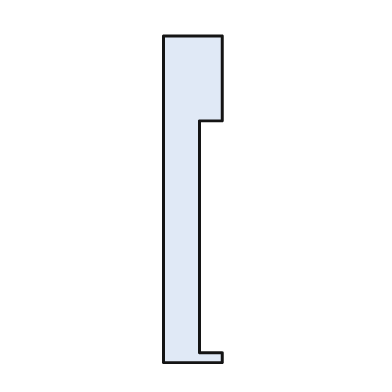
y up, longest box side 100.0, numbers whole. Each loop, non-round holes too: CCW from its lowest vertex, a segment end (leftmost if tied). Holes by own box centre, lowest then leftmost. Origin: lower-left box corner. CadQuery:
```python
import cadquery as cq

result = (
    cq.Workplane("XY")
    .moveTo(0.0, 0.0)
    .lineTo(18.0, 0.0)
    .lineTo(18.0, 3.0)
    .lineTo(11.0, 3.0)
    .lineTo(11.0, 74.0)
    .lineTo(18.0, 74.0)
    .lineTo(18.0, 100.0)
    .lineTo(0.0, 100.0)
    .close()
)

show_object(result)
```